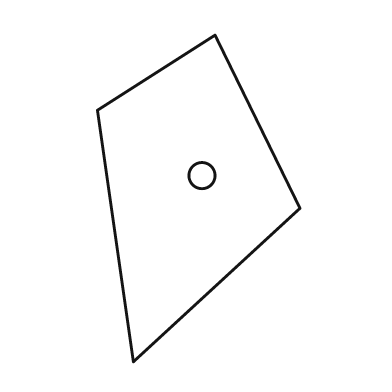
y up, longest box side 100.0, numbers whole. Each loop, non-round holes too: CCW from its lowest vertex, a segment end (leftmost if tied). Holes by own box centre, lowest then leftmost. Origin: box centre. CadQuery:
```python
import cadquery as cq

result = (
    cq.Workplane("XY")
    .moveTo(-20.0, -50.0)
    .lineTo(31.0, -3.0)
    .lineTo(5.0, 50.0)
    .lineTo(-31.0, 27.0)
    .close()
    .moveTo(1.0, 7.0)
    .circle(4.0)
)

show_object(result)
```